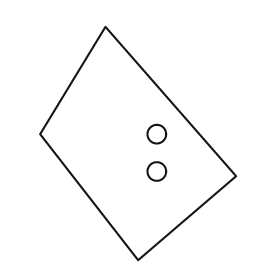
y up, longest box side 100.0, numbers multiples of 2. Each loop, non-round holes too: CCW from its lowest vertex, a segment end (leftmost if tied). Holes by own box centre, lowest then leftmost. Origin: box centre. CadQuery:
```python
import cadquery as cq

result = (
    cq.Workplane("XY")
    .moveTo(0.0, -50.0)
    .lineTo(42.0, -14.0)
    .lineTo(-14.0, 50.0)
    .lineTo(-42.0, 4.0)
    .close()
    .moveTo(8.0, -12.0)
    .circle(4.0)
    .moveTo(8.0, 4.0)
    .circle(4.0)
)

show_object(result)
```